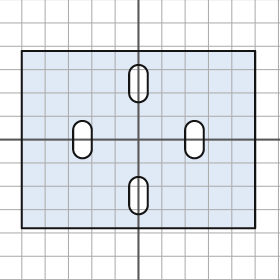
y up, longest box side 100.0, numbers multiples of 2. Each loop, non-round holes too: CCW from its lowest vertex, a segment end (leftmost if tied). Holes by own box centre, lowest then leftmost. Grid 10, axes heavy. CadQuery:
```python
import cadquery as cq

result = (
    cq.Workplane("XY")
    .moveTo(-50.0, -38.0)
    .lineTo(50.0, -38.0)
    .lineTo(50.0, 38.0)
    .lineTo(-50.0, 38.0)
    .close()
    .moveTo(-4.0, -28.0)
    .threePointArc((0.0, -32.0), (4.0, -28.0))
    .lineTo(4.0, -20.0)
    .threePointArc((0.0, -16.0), (-4.0, -20.0))
    .close()
    .moveTo(-28.0, -4.0)
    .threePointArc((-24.0, -8.0), (-20.0, -4.0))
    .lineTo(-20.0, 4.0)
    .threePointArc((-24.0, 8.0), (-28.0, 4.0))
    .close()
    .moveTo(20.0, -4.0)
    .threePointArc((24.0, -8.0), (28.0, -4.0))
    .lineTo(28.0, 4.0)
    .threePointArc((24.0, 8.0), (20.0, 4.0))
    .close()
    .moveTo(-4.0, 20.0)
    .threePointArc((0.0, 16.0), (4.0, 20.0))
    .lineTo(4.0, 28.0)
    .threePointArc((0.0, 32.0), (-4.0, 28.0))
    .close()
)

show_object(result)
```